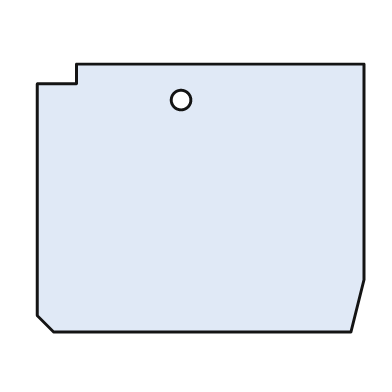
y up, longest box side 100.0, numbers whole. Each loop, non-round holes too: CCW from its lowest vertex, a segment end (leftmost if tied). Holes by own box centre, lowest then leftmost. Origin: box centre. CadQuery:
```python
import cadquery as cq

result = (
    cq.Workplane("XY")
    .moveTo(-45.0, -41.0)
    .lineTo(46.0, -41.0)
    .lineTo(50.0, -25.0)
    .lineTo(50.0, 41.0)
    .lineTo(-38.0, 41.0)
    .lineTo(-38.0, 35.0)
    .lineTo(-50.0, 35.0)
    .lineTo(-50.0, -36.0)
    .close()
    .moveTo(-6.0, 30.0)
    .circle(3.0)
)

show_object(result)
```